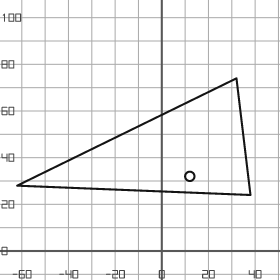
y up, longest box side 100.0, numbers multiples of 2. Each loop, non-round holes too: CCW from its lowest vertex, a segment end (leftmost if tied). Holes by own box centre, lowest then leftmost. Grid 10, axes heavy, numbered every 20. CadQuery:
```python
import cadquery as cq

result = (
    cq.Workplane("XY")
    .moveTo(38.0, 24.0)
    .lineTo(32.0, 74.0)
    .lineTo(-62.0, 28.0)
    .close()
    .moveTo(12.0, 32.0)
    .circle(2.0)
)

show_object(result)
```